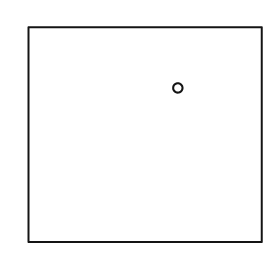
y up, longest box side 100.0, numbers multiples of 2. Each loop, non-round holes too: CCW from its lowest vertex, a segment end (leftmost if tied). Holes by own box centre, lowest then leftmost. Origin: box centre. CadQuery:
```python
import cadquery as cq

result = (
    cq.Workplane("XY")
    .moveTo(-50.0, -46.0)
    .lineTo(50.0, -46.0)
    .lineTo(50.0, 46.0)
    .lineTo(-50.0, 46.0)
    .close()
    .moveTo(14.0, 20.0)
    .circle(2.0)
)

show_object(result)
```